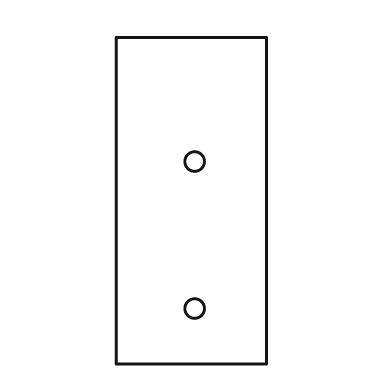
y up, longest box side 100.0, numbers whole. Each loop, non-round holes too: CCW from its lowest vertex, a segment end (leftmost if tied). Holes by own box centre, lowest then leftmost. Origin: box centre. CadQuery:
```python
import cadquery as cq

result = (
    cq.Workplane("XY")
    .moveTo(-23.0, -50.0)
    .lineTo(23.0, -50.0)
    .lineTo(23.0, 50.0)
    .lineTo(-23.0, 50.0)
    .close()
    .moveTo(1.0, -33.0)
    .circle(3.0)
    .moveTo(1.0, 12.0)
    .circle(3.0)
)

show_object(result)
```